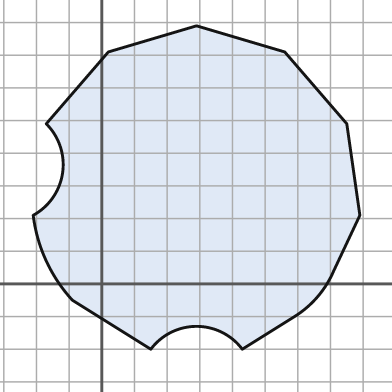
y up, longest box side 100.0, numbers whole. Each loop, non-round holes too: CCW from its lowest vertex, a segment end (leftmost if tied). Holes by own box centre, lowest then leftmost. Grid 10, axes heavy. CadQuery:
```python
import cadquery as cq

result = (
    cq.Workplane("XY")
    .moveTo(15.0, -20.0)
    .threePointArc((29.0, -13.0), (43.0, -20.0))
    .lineTo(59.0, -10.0)
    .threePointArc((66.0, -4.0), (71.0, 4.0))
    .lineTo(79.0, 21.0)
    .lineTo(75.0, 49.0)
    .lineTo(56.0, 71.0)
    .lineTo(29.0, 79.0)
    .lineTo(2.0, 71.0)
    .lineTo(-17.0, 49.0)
    .threePointArc((-12.0, 34.0), (-21.0, 21.0))
    .threePointArc((-17.0, 7.0), (-9.0, -5.0))
    .close()
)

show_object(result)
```